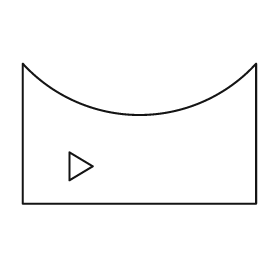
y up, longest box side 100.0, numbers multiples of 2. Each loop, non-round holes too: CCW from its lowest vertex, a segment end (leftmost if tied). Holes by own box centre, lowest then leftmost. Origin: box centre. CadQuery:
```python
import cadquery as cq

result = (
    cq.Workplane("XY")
    .moveTo(-50.0, -30.0)
    .lineTo(50.0, -30.0)
    .lineTo(50.0, 30.0)
    .threePointArc((0.0, 8.0), (-50.0, 30.0))
    .close()
    .moveTo(-30.0, -20.0)
    .lineTo(-20.0, -14.0)
    .lineTo(-30.0, -8.0)
    .close()
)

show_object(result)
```